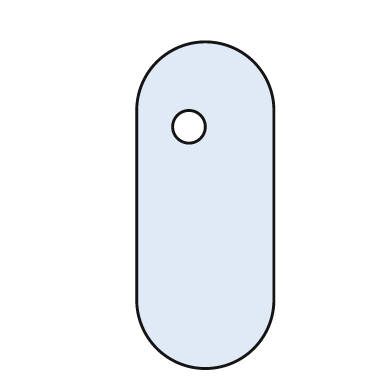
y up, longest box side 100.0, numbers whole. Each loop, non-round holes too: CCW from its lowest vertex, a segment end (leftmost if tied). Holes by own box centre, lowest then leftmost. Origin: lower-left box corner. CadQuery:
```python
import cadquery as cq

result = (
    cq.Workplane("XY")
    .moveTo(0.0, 21.0)
    .threePointArc((21.0, 0.0), (42.0, 21.0))
    .lineTo(42.0, 79.0)
    .threePointArc((21.0, 100.0), (0.0, 79.0))
    .close()
    .moveTo(16.0, 74.0)
    .circle(5.0)
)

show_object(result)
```